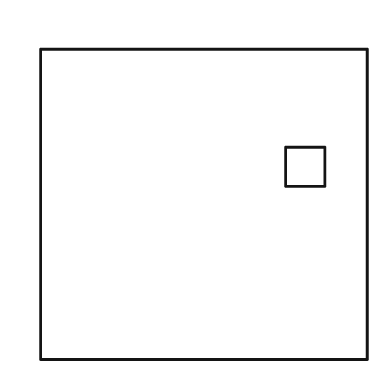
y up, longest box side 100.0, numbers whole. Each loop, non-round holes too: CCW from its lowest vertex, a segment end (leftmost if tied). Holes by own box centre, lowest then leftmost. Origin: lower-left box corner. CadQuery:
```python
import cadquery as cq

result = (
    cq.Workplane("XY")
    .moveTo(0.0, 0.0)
    .lineTo(100.0, 0.0)
    .lineTo(100.0, 95.0)
    .lineTo(0.0, 95.0)
    .close()
    .moveTo(75.0, 53.0)
    .lineTo(87.0, 53.0)
    .lineTo(87.0, 65.0)
    .lineTo(75.0, 65.0)
    .close()
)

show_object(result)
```